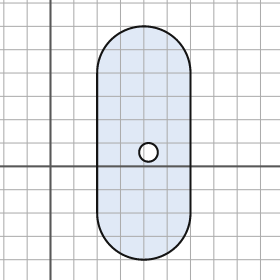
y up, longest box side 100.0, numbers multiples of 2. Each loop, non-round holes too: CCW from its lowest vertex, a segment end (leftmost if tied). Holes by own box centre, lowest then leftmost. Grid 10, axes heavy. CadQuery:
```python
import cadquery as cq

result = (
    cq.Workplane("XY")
    .moveTo(20.0, -20.0)
    .threePointArc((40.0, -40.0), (60.0, -20.0))
    .lineTo(60.0, 40.0)
    .threePointArc((40.0, 60.0), (20.0, 40.0))
    .close()
    .moveTo(42.0, 6.0)
    .circle(4.0)
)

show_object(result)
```